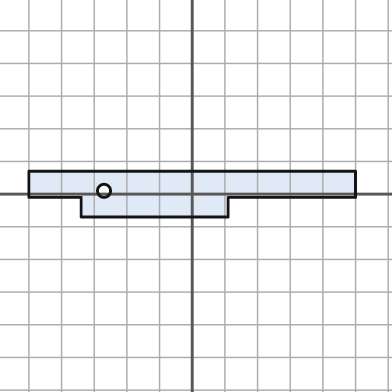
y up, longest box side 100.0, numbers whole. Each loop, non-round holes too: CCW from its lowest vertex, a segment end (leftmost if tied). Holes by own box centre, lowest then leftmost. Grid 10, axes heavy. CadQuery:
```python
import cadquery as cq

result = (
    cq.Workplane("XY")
    .moveTo(-34.0, -7.0)
    .lineTo(11.0, -7.0)
    .lineTo(11.0, -1.0)
    .lineTo(50.0, -1.0)
    .lineTo(50.0, 7.0)
    .lineTo(-50.0, 7.0)
    .lineTo(-50.0, -1.0)
    .lineTo(-34.0, -1.0)
    .close()
    .moveTo(-27.0, 1.0)
    .circle(2.0)
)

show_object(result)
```